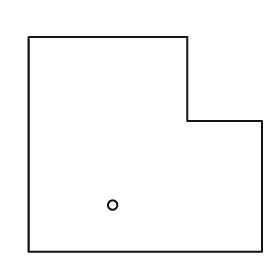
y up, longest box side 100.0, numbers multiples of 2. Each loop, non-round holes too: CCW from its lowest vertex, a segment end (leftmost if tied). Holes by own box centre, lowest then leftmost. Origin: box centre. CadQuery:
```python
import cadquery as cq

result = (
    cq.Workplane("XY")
    .moveTo(-50.0, -46.0)
    .lineTo(50.0, -46.0)
    .lineTo(50.0, 10.0)
    .lineTo(18.0, 10.0)
    .lineTo(18.0, 46.0)
    .lineTo(-50.0, 46.0)
    .close()
    .moveTo(-14.0, -26.0)
    .circle(2.0)
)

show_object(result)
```